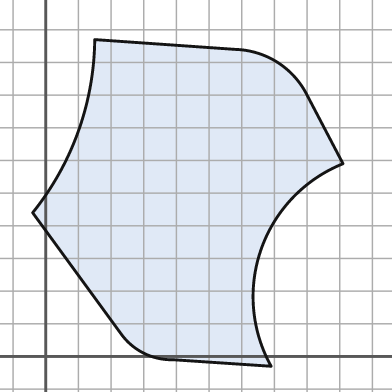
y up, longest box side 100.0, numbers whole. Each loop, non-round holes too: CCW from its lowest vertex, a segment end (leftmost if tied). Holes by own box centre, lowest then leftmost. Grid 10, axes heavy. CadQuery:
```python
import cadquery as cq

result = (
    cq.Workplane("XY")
    .moveTo(69.0, -3.0)
    .threePointArc((66.0, 33.0), (91.0, 59.0))
    .lineTo(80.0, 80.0)
    .threePointArc((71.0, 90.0), (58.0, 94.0))
    .lineTo(15.0, 97.0)
    .threePointArc((10.0, 69.0), (-4.0, 44.0))
    .lineTo(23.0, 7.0)
    .threePointArc((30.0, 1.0), (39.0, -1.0))
    .close()
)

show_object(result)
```